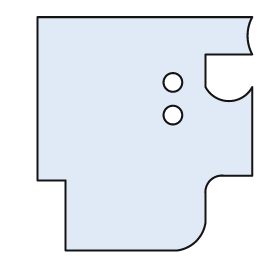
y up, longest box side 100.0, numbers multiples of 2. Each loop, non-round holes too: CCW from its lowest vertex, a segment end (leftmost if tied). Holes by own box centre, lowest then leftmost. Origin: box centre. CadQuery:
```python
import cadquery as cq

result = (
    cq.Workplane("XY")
    .moveTo(-34.0, -50.0)
    .lineTo(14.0, -50.0)
    .threePointArc((22.0, -46.0), (26.0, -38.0))
    .lineTo(26.0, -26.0)
    .threePointArc((28.0, -20.0), (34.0, -18.0))
    .lineTo(46.0, -18.0)
    .lineTo(46.0, 20.0)
    .threePointArc((36.0, 14.0), (26.0, 20.0))
    .lineTo(26.0, 34.0)
    .lineTo(46.0, 34.0)
    .threePointArc((44.0, 42.0), (46.0, 50.0))
    .lineTo(-46.0, 50.0)
    .lineTo(-46.0, -20.0)
    .lineTo(-34.0, -20.0)
    .close()
    .moveTo(12.0, 8.0)
    .circle(4.0)
    .moveTo(12.0, 22.0)
    .circle(4.0)
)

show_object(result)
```